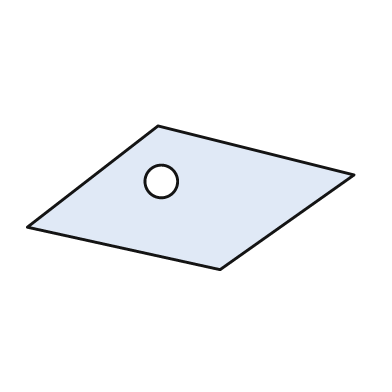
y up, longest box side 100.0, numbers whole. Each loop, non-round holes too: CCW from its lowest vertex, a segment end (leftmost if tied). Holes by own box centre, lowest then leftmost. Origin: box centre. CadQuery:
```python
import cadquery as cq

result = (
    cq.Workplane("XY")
    .moveTo(9.0, -22.0)
    .lineTo(50.0, 7.0)
    .lineTo(-10.0, 22.0)
    .lineTo(-50.0, -9.0)
    .close()
    .moveTo(-9.0, 5.0)
    .circle(5.0)
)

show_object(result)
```